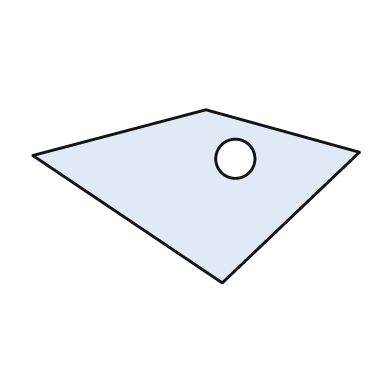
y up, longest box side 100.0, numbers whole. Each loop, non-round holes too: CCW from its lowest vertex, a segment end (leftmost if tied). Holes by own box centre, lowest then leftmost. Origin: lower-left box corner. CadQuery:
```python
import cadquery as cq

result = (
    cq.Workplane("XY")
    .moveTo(58.0, 0.0)
    .lineTo(100.0, 40.0)
    .lineTo(53.0, 53.0)
    .lineTo(0.0, 39.0)
    .close()
    .moveTo(62.0, 38.0)
    .circle(6.0)
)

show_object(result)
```